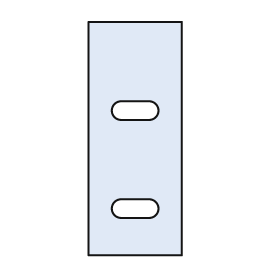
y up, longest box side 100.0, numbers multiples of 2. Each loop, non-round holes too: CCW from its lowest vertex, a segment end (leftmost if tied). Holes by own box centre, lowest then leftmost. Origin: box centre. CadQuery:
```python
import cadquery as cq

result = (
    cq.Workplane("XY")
    .moveTo(-20.0, -50.0)
    .lineTo(20.0, -50.0)
    .lineTo(20.0, 50.0)
    .lineTo(-20.0, 50.0)
    .close()
    .moveTo(-6.0, -34.0)
    .lineTo(6.0, -34.0)
    .threePointArc((10.0, -30.0), (6.0, -26.0))
    .lineTo(-6.0, -26.0)
    .threePointArc((-10.0, -30.0), (-6.0, -34.0))
    .close()
    .moveTo(-6.0, 8.0)
    .lineTo(6.0, 8.0)
    .threePointArc((10.0, 12.0), (6.0, 16.0))
    .lineTo(-6.0, 16.0)
    .threePointArc((-10.0, 12.0), (-6.0, 8.0))
    .close()
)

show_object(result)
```